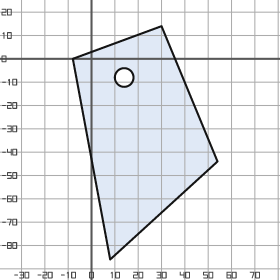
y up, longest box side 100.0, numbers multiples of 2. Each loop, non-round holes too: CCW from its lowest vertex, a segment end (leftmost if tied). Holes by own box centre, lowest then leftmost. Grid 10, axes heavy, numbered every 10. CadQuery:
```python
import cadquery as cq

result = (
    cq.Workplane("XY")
    .moveTo(8.0, -86.0)
    .lineTo(54.0, -44.0)
    .lineTo(30.0, 14.0)
    .lineTo(-8.0, 0.0)
    .close()
    .moveTo(14.0, -8.0)
    .circle(4.0)
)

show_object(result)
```